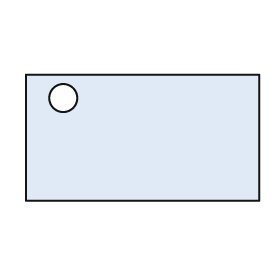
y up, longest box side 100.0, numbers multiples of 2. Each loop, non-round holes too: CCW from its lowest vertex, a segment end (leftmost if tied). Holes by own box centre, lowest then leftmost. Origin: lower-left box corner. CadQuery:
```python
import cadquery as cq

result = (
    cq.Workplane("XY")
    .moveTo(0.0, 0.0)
    .lineTo(100.0, 0.0)
    .lineTo(100.0, 54.0)
    .lineTo(0.0, 54.0)
    .close()
    .moveTo(16.0, 44.0)
    .circle(6.0)
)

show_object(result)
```